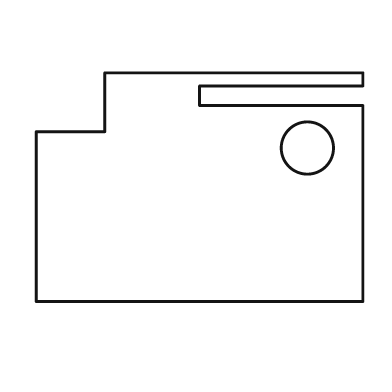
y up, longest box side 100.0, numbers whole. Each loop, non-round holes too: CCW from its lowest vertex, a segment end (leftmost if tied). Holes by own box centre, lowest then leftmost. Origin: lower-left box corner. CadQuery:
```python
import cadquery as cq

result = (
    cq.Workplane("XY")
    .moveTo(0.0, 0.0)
    .lineTo(100.0, 0.0)
    .lineTo(100.0, 60.0)
    .lineTo(50.0, 60.0)
    .lineTo(50.0, 66.0)
    .lineTo(100.0, 66.0)
    .lineTo(100.0, 70.0)
    .lineTo(21.0, 70.0)
    .lineTo(21.0, 52.0)
    .lineTo(0.0, 52.0)
    .close()
    .moveTo(83.0, 47.0)
    .circle(8.0)
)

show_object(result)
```